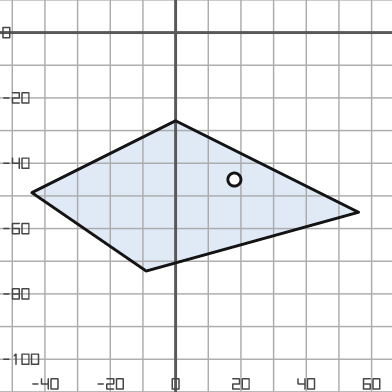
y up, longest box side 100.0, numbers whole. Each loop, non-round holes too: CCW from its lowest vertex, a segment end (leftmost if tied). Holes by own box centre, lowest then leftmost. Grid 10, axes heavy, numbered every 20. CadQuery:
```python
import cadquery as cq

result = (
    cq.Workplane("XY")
    .moveTo(-9.0, -73.0)
    .lineTo(56.0, -55.0)
    .lineTo(0.0, -27.0)
    .lineTo(-44.0, -49.0)
    .close()
    .moveTo(18.0, -45.0)
    .circle(2.0)
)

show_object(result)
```